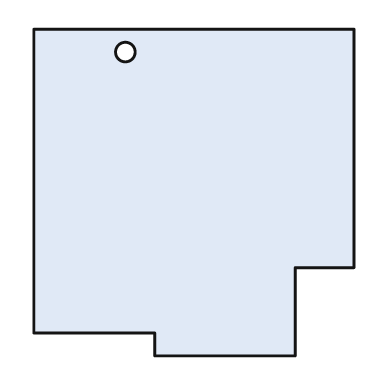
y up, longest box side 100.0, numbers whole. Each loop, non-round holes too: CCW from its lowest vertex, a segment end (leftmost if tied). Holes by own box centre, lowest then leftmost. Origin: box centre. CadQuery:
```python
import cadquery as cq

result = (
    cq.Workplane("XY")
    .moveTo(-12.0, -50.0)
    .lineTo(31.0, -50.0)
    .lineTo(31.0, -23.0)
    .lineTo(49.0, -23.0)
    .lineTo(49.0, 50.0)
    .lineTo(-49.0, 50.0)
    .lineTo(-49.0, -43.0)
    .lineTo(-12.0, -43.0)
    .close()
    .moveTo(-21.0, 43.0)
    .circle(3.0)
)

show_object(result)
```